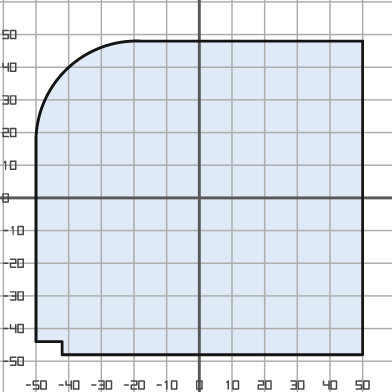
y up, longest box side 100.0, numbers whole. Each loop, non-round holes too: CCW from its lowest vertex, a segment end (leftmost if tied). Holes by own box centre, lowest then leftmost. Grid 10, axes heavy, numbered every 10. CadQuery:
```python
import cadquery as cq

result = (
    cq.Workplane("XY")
    .moveTo(-42.0, -48.0)
    .lineTo(50.0, -48.0)
    .lineTo(50.0, 48.0)
    .lineTo(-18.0, 48.0)
    .threePointArc((-41.0, 39.0), (-50.0, 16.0))
    .lineTo(-50.0, -44.0)
    .lineTo(-42.0, -44.0)
    .close()
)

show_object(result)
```